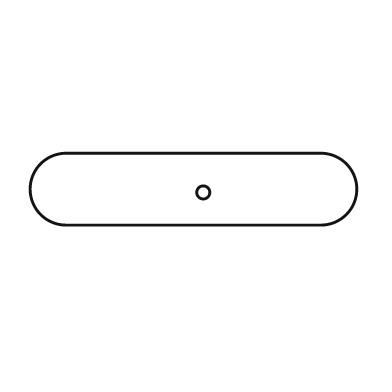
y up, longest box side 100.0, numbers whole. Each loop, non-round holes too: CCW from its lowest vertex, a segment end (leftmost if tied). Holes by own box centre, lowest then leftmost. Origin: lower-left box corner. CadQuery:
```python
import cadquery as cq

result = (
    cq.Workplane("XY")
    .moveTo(11.0, 0.0)
    .lineTo(89.0, 0.0)
    .threePointArc((100.0, 11.0), (89.0, 22.0))
    .lineTo(11.0, 22.0)
    .threePointArc((0.0, 11.0), (11.0, 0.0))
    .close()
    .moveTo(53.0, 10.0)
    .circle(2.0)
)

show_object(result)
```